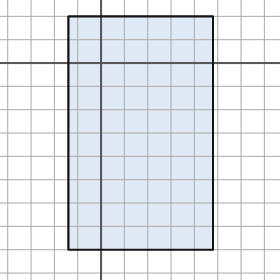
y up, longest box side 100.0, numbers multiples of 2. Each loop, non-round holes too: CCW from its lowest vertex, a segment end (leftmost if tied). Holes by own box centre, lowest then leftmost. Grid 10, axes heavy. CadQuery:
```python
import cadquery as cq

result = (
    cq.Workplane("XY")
    .moveTo(-14.0, -80.0)
    .lineTo(48.0, -80.0)
    .lineTo(48.0, 20.0)
    .lineTo(-14.0, 20.0)
    .close()
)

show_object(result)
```